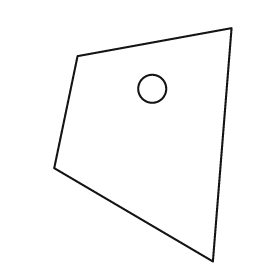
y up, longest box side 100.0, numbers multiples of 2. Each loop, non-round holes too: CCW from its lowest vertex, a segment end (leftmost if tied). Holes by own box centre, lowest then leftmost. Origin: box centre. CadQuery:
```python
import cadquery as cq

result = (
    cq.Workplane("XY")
    .moveTo(30.0, -50.0)
    .lineTo(38.0, 50.0)
    .lineTo(-28.0, 38.0)
    .lineTo(-38.0, -10.0)
    .close()
    .moveTo(4.0, 24.0)
    .circle(6.0)
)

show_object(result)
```